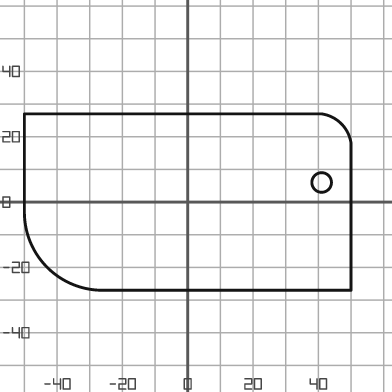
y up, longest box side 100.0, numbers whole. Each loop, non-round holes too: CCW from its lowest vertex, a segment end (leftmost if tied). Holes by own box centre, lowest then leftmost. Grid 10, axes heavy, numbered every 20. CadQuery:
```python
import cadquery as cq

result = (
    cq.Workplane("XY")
    .moveTo(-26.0, -27.0)
    .lineTo(50.0, -27.0)
    .lineTo(50.0, 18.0)
    .threePointArc((47.0, 24.0), (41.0, 27.0))
    .lineTo(-50.0, 27.0)
    .lineTo(-50.0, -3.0)
    .threePointArc((-43.0, -20.0), (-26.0, -27.0))
    .close()
    .moveTo(41.0, 6.0)
    .circle(3.0)
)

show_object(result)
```